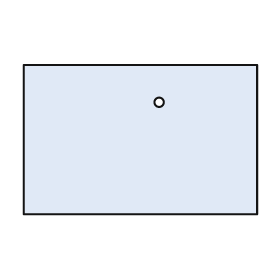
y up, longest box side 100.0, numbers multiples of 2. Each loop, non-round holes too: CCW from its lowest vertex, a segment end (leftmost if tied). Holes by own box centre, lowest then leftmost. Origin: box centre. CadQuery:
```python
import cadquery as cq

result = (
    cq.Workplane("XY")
    .moveTo(-50.0, -32.0)
    .lineTo(50.0, -32.0)
    .lineTo(50.0, 32.0)
    .lineTo(-50.0, 32.0)
    .close()
    .moveTo(8.0, 16.0)
    .circle(2.0)
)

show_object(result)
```